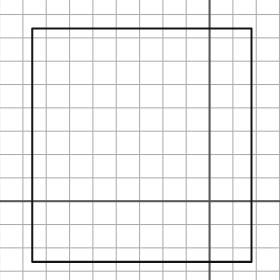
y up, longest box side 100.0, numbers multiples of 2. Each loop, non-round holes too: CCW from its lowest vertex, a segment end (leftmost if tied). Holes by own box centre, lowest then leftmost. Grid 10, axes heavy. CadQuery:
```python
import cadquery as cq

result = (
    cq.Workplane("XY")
    .moveTo(-76.0, -26.0)
    .lineTo(18.0, -26.0)
    .lineTo(18.0, 74.0)
    .lineTo(-76.0, 74.0)
    .close()
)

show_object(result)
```